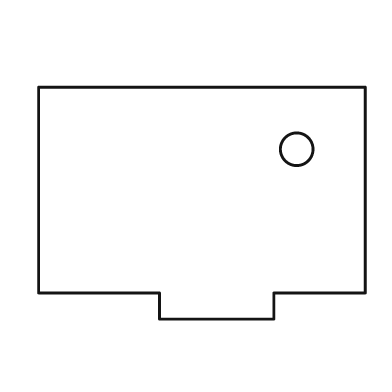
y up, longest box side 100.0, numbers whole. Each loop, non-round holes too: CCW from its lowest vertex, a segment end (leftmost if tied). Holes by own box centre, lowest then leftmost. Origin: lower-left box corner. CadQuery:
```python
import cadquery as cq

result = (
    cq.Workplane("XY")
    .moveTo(37.0, 0.0)
    .lineTo(72.0, 0.0)
    .lineTo(72.0, 8.0)
    .lineTo(100.0, 8.0)
    .lineTo(100.0, 71.0)
    .lineTo(0.0, 71.0)
    .lineTo(0.0, 8.0)
    .lineTo(37.0, 8.0)
    .close()
    .moveTo(79.0, 52.0)
    .circle(5.0)
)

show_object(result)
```